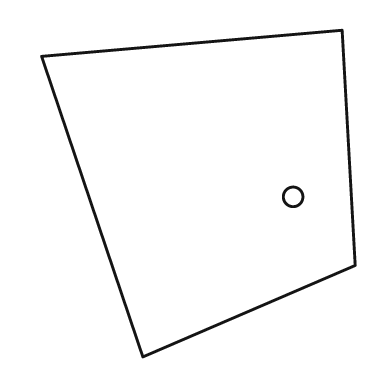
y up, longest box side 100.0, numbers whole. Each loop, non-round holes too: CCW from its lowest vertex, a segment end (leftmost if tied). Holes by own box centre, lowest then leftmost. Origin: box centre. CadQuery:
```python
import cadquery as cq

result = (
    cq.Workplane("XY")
    .moveTo(-17.0, -50.0)
    .lineTo(48.0, -22.0)
    .lineTo(44.0, 50.0)
    .lineTo(-48.0, 42.0)
    .close()
    .moveTo(29.0, -1.0)
    .circle(3.0)
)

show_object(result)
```